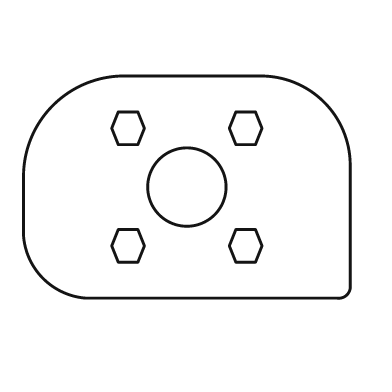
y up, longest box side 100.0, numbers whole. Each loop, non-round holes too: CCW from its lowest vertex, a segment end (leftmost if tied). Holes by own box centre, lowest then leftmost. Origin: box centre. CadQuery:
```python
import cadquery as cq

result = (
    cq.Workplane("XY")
    .moveTo(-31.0, -34.0)
    .lineTo(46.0, -34.0)
    .threePointArc((49.0, -33.0), (50.0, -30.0))
    .lineTo(50.0, 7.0)
    .threePointArc((42.0, 26.0), (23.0, 34.0))
    .lineTo(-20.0, 34.0)
    .threePointArc((-41.0, 25.0), (-50.0, 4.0))
    .lineTo(-50.0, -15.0)
    .threePointArc((-44.0, -28.0), (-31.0, -34.0))
    .close()
    .moveTo(-21.0, -23.0)
    .lineTo(-15.0, -23.0)
    .lineTo(-13.0, -18.0)
    .lineTo(-15.0, -13.0)
    .lineTo(-21.0, -13.0)
    .lineTo(-23.0, -18.0)
    .close()
    .moveTo(15.0, -23.0)
    .lineTo(21.0, -23.0)
    .lineTo(23.0, -18.0)
    .lineTo(21.0, -13.0)
    .lineTo(15.0, -13.0)
    .lineTo(13.0, -18.0)
    .close()
    .moveTo(0.0, 0.0)
    .circle(12.0)
    .moveTo(-21.0, 13.0)
    .lineTo(-15.0, 13.0)
    .lineTo(-13.0, 18.0)
    .lineTo(-15.0, 23.0)
    .lineTo(-21.0, 23.0)
    .lineTo(-23.0, 18.0)
    .close()
    .moveTo(15.0, 13.0)
    .lineTo(21.0, 13.0)
    .lineTo(23.0, 18.0)
    .lineTo(21.0, 23.0)
    .lineTo(15.0, 23.0)
    .lineTo(13.0, 18.0)
    .close()
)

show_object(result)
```